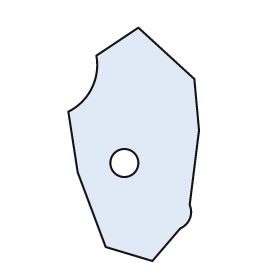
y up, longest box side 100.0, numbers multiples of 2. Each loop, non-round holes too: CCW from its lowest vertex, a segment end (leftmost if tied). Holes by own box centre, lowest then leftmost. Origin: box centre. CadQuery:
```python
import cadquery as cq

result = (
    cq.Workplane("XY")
    .moveTo(8.0, -50.0)
    .lineTo(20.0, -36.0)
    .threePointArc((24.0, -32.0), (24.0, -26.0))
    .lineTo(28.0, 6.0)
    .lineTo(26.0, 28.0)
    .lineTo(2.0, 50.0)
    .lineTo(-16.0, 38.0)
    .threePointArc((-18.0, 24.0), (-28.0, 14.0))
    .lineTo(-24.0, -12.0)
    .lineTo(-12.0, -44.0)
    .close()
    .moveTo(-4.0, -8.0)
    .circle(6.0)
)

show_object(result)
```